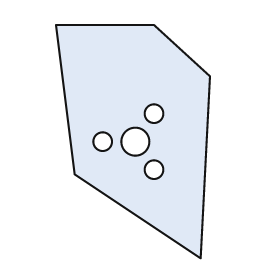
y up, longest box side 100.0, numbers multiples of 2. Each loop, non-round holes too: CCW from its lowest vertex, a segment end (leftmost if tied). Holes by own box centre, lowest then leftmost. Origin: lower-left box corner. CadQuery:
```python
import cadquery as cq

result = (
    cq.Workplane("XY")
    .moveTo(62.0, 0.0)
    .lineTo(66.0, 78.0)
    .lineTo(42.0, 100.0)
    .lineTo(0.0, 100.0)
    .lineTo(8.0, 36.0)
    .close()
    .moveTo(42.0, 38.0)
    .circle(4.0)
    .moveTo(20.0, 50.0)
    .circle(4.0)
    .moveTo(34.0, 50.0)
    .circle(6.0)
    .moveTo(42.0, 62.0)
    .circle(4.0)
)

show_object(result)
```